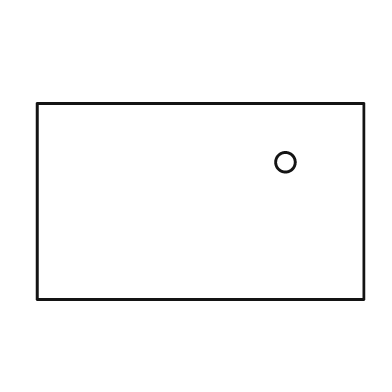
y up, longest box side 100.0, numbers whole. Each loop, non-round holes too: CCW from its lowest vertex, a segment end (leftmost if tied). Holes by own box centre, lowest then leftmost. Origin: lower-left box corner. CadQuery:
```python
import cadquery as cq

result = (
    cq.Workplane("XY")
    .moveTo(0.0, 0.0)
    .lineTo(100.0, 0.0)
    .lineTo(100.0, 60.0)
    .lineTo(0.0, 60.0)
    .close()
    .moveTo(76.0, 42.0)
    .circle(3.0)
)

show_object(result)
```